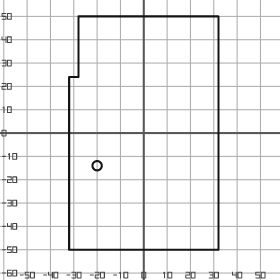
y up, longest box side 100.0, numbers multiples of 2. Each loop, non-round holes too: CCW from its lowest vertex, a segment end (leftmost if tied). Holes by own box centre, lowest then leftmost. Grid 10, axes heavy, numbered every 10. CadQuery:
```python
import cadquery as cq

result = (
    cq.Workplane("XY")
    .moveTo(-32.0, -50.0)
    .lineTo(32.0, -50.0)
    .lineTo(32.0, 50.0)
    .lineTo(-28.0, 50.0)
    .lineTo(-28.0, 24.0)
    .lineTo(-32.0, 24.0)
    .close()
    .moveTo(-20.0, -14.0)
    .circle(2.0)
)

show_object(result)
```